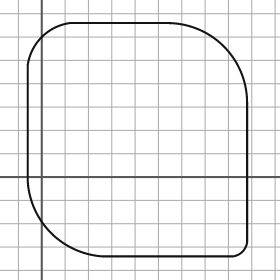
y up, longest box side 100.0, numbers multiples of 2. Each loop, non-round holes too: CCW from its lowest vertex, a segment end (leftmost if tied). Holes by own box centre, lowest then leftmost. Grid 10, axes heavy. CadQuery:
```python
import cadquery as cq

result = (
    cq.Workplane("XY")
    .moveTo(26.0, -34.0)
    .lineTo(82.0, -34.0)
    .threePointArc((86.0, -32.0), (88.0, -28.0))
    .lineTo(88.0, 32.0)
    .threePointArc((78.0, 56.0), (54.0, 66.0))
    .lineTo(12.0, 66.0)
    .threePointArc((0.0, 60.0), (-6.0, 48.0))
    .lineTo(-6.0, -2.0)
    .threePointArc((4.0, -24.0), (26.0, -34.0))
    .close()
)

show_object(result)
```